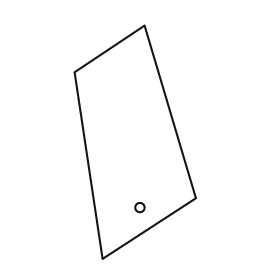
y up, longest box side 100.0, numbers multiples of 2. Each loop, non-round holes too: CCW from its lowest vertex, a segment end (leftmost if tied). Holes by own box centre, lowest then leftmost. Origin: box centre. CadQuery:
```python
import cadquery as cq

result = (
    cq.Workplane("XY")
    .moveTo(-14.0, -50.0)
    .lineTo(26.0, -24.0)
    .lineTo(4.0, 50.0)
    .lineTo(-26.0, 30.0)
    .close()
    .moveTo(2.0, -28.0)
    .circle(2.0)
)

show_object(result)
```